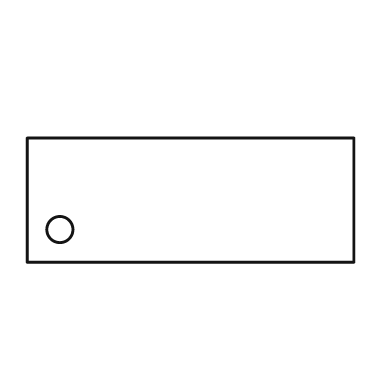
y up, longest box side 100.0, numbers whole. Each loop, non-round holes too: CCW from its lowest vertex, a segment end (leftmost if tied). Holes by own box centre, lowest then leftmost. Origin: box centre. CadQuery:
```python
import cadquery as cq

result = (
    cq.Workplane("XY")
    .moveTo(-50.0, -19.0)
    .lineTo(50.0, -19.0)
    .lineTo(50.0, 19.0)
    .lineTo(-50.0, 19.0)
    .close()
    .moveTo(-40.0, -9.0)
    .circle(4.0)
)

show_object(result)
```